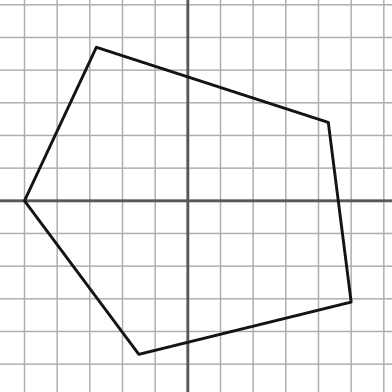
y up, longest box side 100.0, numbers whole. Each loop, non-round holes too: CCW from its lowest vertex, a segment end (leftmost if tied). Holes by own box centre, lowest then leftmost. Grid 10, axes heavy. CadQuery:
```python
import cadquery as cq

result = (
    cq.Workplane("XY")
    .moveTo(-15.0, -47.0)
    .lineTo(50.0, -31.0)
    .lineTo(43.0, 24.0)
    .lineTo(-28.0, 47.0)
    .lineTo(-50.0, 0.0)
    .close()
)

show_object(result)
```